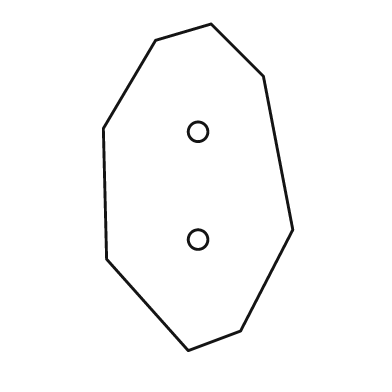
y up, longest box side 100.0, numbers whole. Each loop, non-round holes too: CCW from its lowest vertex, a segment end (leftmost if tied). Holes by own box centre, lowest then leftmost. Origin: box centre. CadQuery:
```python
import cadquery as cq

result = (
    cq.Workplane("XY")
    .moveTo(-3.0, -50.0)
    .lineTo(13.0, -44.0)
    .lineTo(29.0, -13.0)
    .lineTo(20.0, 34.0)
    .lineTo(4.0, 50.0)
    .lineTo(-13.0, 45.0)
    .lineTo(-29.0, 18.0)
    .lineTo(-28.0, -22.0)
    .close()
    .moveTo(0.0, -16.0)
    .circle(3.0)
    .moveTo(0.0, 17.0)
    .circle(3.0)
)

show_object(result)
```